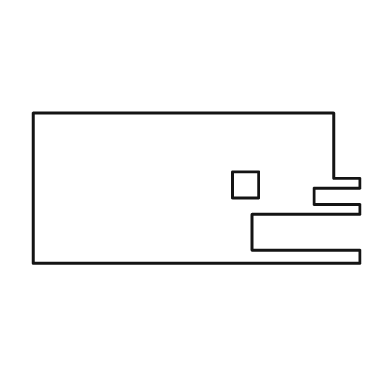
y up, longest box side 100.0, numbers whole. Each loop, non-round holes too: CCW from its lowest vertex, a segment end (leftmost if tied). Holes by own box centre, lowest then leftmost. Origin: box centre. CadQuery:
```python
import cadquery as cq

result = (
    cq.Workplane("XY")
    .moveTo(-50.0, -23.0)
    .lineTo(50.0, -23.0)
    .lineTo(50.0, -19.0)
    .lineTo(17.0, -19.0)
    .lineTo(17.0, -8.0)
    .lineTo(50.0, -8.0)
    .lineTo(50.0, -5.0)
    .lineTo(36.0, -5.0)
    .lineTo(36.0, 0.0)
    .lineTo(50.0, 0.0)
    .lineTo(50.0, 3.0)
    .lineTo(42.0, 3.0)
    .lineTo(42.0, 23.0)
    .lineTo(-50.0, 23.0)
    .close()
    .moveTo(11.0, -3.0)
    .lineTo(19.0, -3.0)
    .lineTo(19.0, 5.0)
    .lineTo(11.0, 5.0)
    .close()
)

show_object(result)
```